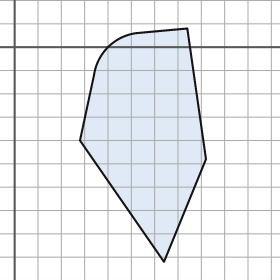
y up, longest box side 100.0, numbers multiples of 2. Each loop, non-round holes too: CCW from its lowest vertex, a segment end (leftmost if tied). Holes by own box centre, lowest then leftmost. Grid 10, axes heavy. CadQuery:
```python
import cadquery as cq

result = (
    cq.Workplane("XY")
    .moveTo(64.0, -92.0)
    .lineTo(82.0, -48.0)
    .lineTo(74.0, 8.0)
    .lineTo(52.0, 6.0)
    .threePointArc((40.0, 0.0), (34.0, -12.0))
    .lineTo(28.0, -40.0)
    .close()
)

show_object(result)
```